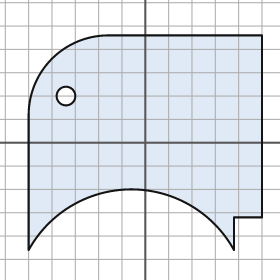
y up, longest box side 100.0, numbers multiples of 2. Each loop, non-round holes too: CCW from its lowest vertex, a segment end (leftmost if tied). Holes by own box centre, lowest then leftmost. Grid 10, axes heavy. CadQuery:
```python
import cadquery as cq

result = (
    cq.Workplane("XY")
    .moveTo(-50.0, -46.0)
    .threePointArc((-6.0, -20.0), (38.0, -46.0))
    .lineTo(38.0, -32.0)
    .lineTo(50.0, -32.0)
    .lineTo(50.0, 46.0)
    .lineTo(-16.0, 46.0)
    .threePointArc((-40.0, 36.0), (-50.0, 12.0))
    .close()
    .moveTo(-34.0, 20.0)
    .circle(4.0)
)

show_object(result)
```